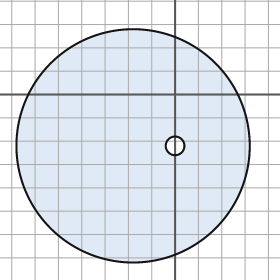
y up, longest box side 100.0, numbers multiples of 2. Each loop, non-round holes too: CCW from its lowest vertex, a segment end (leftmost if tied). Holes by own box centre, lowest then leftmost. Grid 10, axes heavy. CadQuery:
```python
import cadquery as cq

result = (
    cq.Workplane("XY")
    .moveTo(-18.0, -22.0)
    .circle(50.0)
    .moveTo(0.0, -22.0)
    .circle(4.0)
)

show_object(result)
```